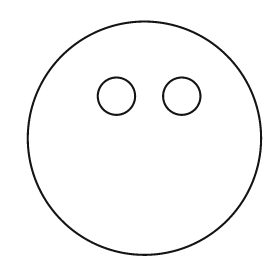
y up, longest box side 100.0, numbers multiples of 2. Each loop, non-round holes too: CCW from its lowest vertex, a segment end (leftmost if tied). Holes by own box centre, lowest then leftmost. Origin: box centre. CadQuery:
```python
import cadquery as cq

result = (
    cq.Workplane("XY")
    .moveTo(0.0, 0.0)
    .circle(50.0)
    .moveTo(-12.0, 18.0)
    .circle(8.0)
    .moveTo(16.0, 18.0)
    .circle(8.0)
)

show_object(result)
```